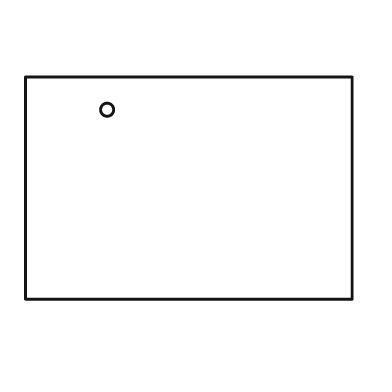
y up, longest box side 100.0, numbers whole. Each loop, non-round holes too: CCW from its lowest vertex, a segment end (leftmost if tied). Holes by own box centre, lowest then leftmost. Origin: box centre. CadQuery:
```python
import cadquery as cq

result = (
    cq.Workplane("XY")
    .moveTo(-50.0, -34.0)
    .lineTo(50.0, -34.0)
    .lineTo(50.0, 34.0)
    .lineTo(-50.0, 34.0)
    .close()
    .moveTo(-25.0, 24.0)
    .circle(2.0)
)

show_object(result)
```